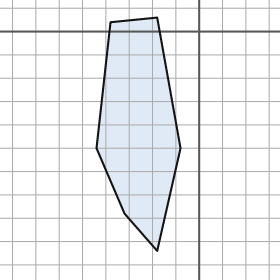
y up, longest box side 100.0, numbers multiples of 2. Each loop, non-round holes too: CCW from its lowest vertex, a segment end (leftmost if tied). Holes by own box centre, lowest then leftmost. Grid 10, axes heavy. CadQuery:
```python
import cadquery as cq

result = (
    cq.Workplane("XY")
    .moveTo(-18.0, -94.0)
    .lineTo(-8.0, -50.0)
    .lineTo(-18.0, 6.0)
    .lineTo(-38.0, 4.0)
    .lineTo(-44.0, -50.0)
    .lineTo(-32.0, -78.0)
    .close()
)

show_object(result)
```